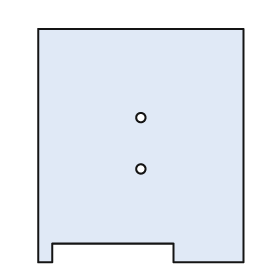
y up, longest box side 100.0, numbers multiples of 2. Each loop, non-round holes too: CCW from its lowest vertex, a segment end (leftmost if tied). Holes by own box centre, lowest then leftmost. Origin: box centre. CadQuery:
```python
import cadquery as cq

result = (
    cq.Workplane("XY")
    .moveTo(-44.0, -50.0)
    .lineTo(-38.0, -50.0)
    .lineTo(-38.0, -42.0)
    .lineTo(14.0, -42.0)
    .lineTo(14.0, -50.0)
    .lineTo(44.0, -50.0)
    .lineTo(44.0, 50.0)
    .lineTo(-44.0, 50.0)
    .close()
    .moveTo(0.0, -10.0)
    .circle(2.0)
    .moveTo(0.0, 12.0)
    .circle(2.0)
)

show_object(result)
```